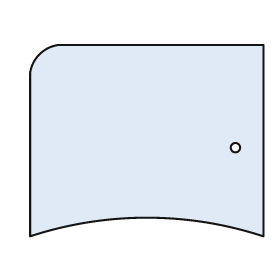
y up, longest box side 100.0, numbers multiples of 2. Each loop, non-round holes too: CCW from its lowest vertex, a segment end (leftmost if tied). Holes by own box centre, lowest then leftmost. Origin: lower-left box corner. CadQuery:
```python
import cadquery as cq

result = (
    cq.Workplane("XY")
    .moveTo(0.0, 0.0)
    .threePointArc((50.0, 8.0), (100.0, 0.0))
    .lineTo(100.0, 82.0)
    .lineTo(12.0, 82.0)
    .threePointArc((4.0, 78.0), (0.0, 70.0))
    .close()
    .moveTo(88.0, 38.0)
    .circle(2.0)
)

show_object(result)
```